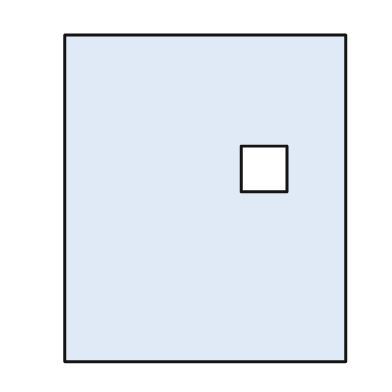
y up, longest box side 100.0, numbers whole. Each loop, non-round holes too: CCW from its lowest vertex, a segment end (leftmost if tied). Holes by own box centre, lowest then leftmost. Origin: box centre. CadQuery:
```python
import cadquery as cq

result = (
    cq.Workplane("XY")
    .moveTo(-43.0, -50.0)
    .lineTo(43.0, -50.0)
    .lineTo(43.0, 50.0)
    .lineTo(-43.0, 50.0)
    .close()
    .moveTo(11.0, 2.0)
    .lineTo(25.0, 2.0)
    .lineTo(25.0, 16.0)
    .lineTo(11.0, 16.0)
    .close()
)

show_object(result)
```